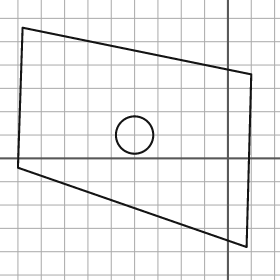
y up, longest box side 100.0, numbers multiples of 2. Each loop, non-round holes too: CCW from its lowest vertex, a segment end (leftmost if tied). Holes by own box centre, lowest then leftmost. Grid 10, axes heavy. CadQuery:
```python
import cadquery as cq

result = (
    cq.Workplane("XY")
    .moveTo(8.0, -38.0)
    .lineTo(10.0, 36.0)
    .lineTo(-88.0, 56.0)
    .lineTo(-90.0, -4.0)
    .close()
    .moveTo(-40.0, 10.0)
    .circle(8.0)
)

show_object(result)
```